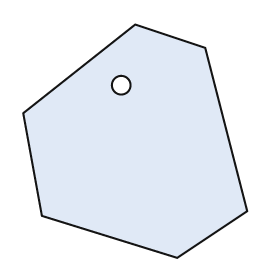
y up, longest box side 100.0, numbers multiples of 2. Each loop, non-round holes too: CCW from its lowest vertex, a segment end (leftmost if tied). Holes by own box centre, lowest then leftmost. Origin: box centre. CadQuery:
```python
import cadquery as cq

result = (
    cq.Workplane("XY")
    .moveTo(18.0, -50.0)
    .lineTo(48.0, -30.0)
    .lineTo(30.0, 40.0)
    .lineTo(0.0, 50.0)
    .lineTo(-48.0, 12.0)
    .lineTo(-40.0, -32.0)
    .close()
    .moveTo(-6.0, 24.0)
    .circle(4.0)
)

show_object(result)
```